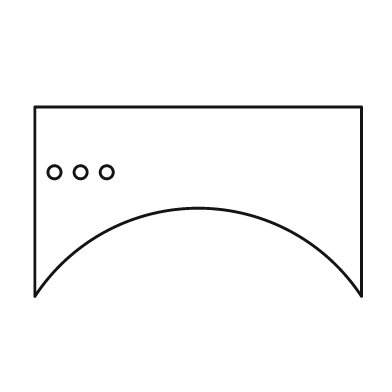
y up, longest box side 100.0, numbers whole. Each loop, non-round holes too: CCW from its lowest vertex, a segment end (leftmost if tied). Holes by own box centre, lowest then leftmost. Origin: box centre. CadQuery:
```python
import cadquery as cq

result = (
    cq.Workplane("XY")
    .moveTo(-50.0, -29.0)
    .threePointArc((0.0, -2.0), (50.0, -29.0))
    .lineTo(50.0, 29.0)
    .lineTo(-50.0, 29.0)
    .close()
    .moveTo(-44.0, 9.0)
    .circle(2.0)
    .moveTo(-36.0, 9.0)
    .circle(2.0)
    .moveTo(-28.0, 9.0)
    .circle(2.0)
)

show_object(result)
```